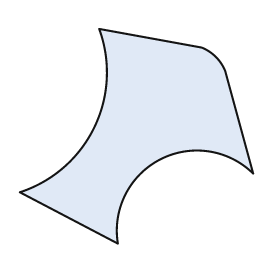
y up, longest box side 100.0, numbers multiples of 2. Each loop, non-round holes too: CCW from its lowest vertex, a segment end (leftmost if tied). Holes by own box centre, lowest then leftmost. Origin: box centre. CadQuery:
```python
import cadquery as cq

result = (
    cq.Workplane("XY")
    .moveTo(-8.0, -46.0)
    .threePointArc((10.0, -10.0), (50.0, -16.0))
    .lineTo(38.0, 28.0)
    .threePointArc((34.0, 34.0), (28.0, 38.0))
    .lineTo(-16.0, 46.0)
    .threePointArc((-18.0, 4.0), (-50.0, -24.0))
    .close()
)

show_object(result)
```